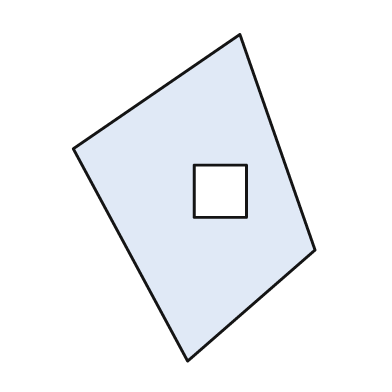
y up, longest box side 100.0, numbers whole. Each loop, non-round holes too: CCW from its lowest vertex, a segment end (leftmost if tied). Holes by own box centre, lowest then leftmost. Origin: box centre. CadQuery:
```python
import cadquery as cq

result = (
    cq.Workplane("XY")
    .moveTo(-2.0, -50.0)
    .lineTo(37.0, -16.0)
    .lineTo(14.0, 50.0)
    .lineTo(-37.0, 15.0)
    .close()
    .moveTo(0.0, -6.0)
    .lineTo(16.0, -6.0)
    .lineTo(16.0, 10.0)
    .lineTo(0.0, 10.0)
    .close()
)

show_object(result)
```